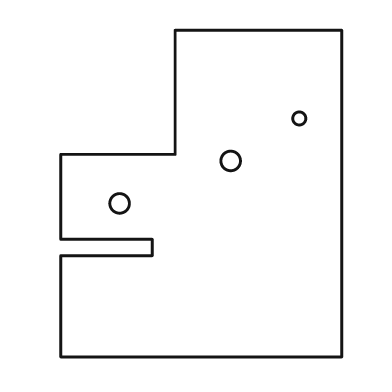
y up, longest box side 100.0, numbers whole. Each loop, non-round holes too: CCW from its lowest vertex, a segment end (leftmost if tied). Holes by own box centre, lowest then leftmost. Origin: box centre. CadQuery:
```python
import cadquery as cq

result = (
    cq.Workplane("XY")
    .moveTo(-43.0, -50.0)
    .lineTo(43.0, -50.0)
    .lineTo(43.0, 50.0)
    .lineTo(-8.0, 50.0)
    .lineTo(-8.0, 12.0)
    .lineTo(-43.0, 12.0)
    .lineTo(-43.0, -14.0)
    .lineTo(-15.0, -14.0)
    .lineTo(-15.0, -19.0)
    .lineTo(-43.0, -19.0)
    .close()
    .moveTo(-25.0, -3.0)
    .circle(3.0)
    .moveTo(9.0, 10.0)
    .circle(3.0)
    .moveTo(30.0, 23.0)
    .circle(2.0)
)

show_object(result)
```